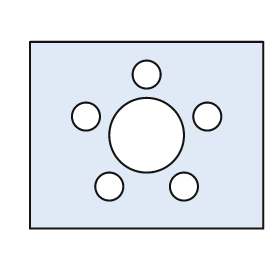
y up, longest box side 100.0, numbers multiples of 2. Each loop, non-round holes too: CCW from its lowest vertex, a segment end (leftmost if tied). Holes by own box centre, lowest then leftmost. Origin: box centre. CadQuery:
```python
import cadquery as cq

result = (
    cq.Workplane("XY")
    .moveTo(-50.0, -40.0)
    .lineTo(50.0, -40.0)
    .lineTo(50.0, 40.0)
    .lineTo(-50.0, 40.0)
    .close()
    .moveTo(-16.0, -22.0)
    .circle(6.0)
    .moveTo(16.0, -22.0)
    .circle(6.0)
    .moveTo(0.0, 0.0)
    .circle(16.0)
    .moveTo(-26.0, 8.0)
    .circle(6.0)
    .moveTo(26.0, 8.0)
    .circle(6.0)
    .moveTo(0.0, 26.0)
    .circle(6.0)
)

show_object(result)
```